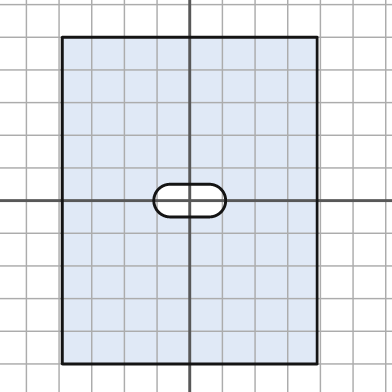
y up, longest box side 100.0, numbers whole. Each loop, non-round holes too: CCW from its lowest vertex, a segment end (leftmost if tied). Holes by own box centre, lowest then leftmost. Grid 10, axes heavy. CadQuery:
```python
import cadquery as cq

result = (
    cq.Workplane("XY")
    .moveTo(-39.0, -50.0)
    .lineTo(39.0, -50.0)
    .lineTo(39.0, 50.0)
    .lineTo(-39.0, 50.0)
    .close()
    .moveTo(-6.0, -5.0)
    .lineTo(6.0, -5.0)
    .threePointArc((11.0, 0.0), (6.0, 5.0))
    .lineTo(-6.0, 5.0)
    .threePointArc((-11.0, 0.0), (-6.0, -5.0))
    .close()
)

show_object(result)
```